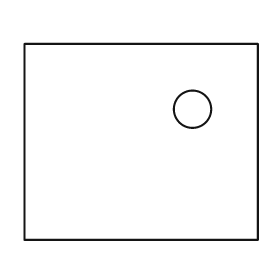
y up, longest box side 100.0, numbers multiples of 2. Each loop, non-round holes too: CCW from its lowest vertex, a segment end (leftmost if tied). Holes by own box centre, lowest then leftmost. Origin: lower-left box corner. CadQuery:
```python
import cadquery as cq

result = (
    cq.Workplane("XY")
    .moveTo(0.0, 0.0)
    .lineTo(100.0, 0.0)
    .lineTo(100.0, 84.0)
    .lineTo(0.0, 84.0)
    .close()
    .moveTo(72.0, 56.0)
    .circle(8.0)
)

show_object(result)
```